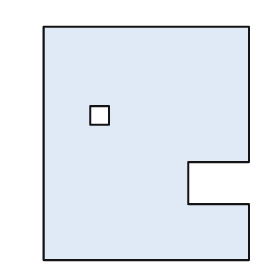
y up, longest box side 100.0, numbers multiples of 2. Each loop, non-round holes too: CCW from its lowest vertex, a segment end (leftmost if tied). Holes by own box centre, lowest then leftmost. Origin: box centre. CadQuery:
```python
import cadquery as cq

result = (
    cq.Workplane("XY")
    .moveTo(-44.0, -50.0)
    .lineTo(44.0, -50.0)
    .lineTo(44.0, -26.0)
    .lineTo(18.0, -26.0)
    .lineTo(18.0, -8.0)
    .lineTo(44.0, -8.0)
    .lineTo(44.0, 50.0)
    .lineTo(-44.0, 50.0)
    .close()
    .moveTo(-24.0, 8.0)
    .lineTo(-16.0, 8.0)
    .lineTo(-16.0, 16.0)
    .lineTo(-24.0, 16.0)
    .close()
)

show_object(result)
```